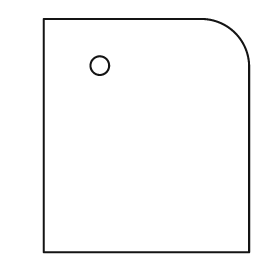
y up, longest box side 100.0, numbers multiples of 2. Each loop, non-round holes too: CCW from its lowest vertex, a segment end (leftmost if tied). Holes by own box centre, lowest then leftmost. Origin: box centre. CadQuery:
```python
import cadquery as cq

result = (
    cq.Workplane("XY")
    .moveTo(-44.0, -50.0)
    .lineTo(44.0, -50.0)
    .lineTo(44.0, 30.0)
    .threePointArc((38.0, 44.0), (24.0, 50.0))
    .lineTo(-44.0, 50.0)
    .close()
    .moveTo(-20.0, 30.0)
    .circle(4.0)
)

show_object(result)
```